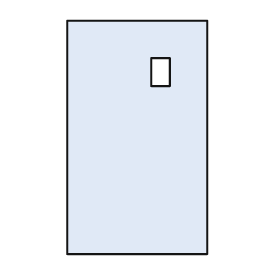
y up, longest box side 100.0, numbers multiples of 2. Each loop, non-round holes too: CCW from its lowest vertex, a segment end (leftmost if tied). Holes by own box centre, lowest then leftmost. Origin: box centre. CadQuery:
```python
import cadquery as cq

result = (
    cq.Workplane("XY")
    .moveTo(-30.0, -50.0)
    .lineTo(30.0, -50.0)
    .lineTo(30.0, 50.0)
    .lineTo(-30.0, 50.0)
    .close()
    .moveTo(6.0, 22.0)
    .lineTo(14.0, 22.0)
    .lineTo(14.0, 34.0)
    .lineTo(6.0, 34.0)
    .close()
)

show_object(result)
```